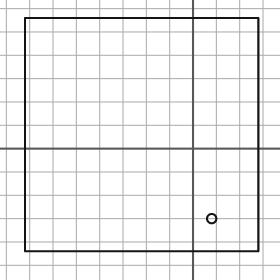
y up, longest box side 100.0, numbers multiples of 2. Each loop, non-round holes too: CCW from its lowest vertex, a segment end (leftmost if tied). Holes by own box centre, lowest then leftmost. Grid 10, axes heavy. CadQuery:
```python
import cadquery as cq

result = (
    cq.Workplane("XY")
    .moveTo(-72.0, -44.0)
    .lineTo(28.0, -44.0)
    .lineTo(28.0, 56.0)
    .lineTo(-72.0, 56.0)
    .close()
    .moveTo(8.0, -30.0)
    .circle(2.0)
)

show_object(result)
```